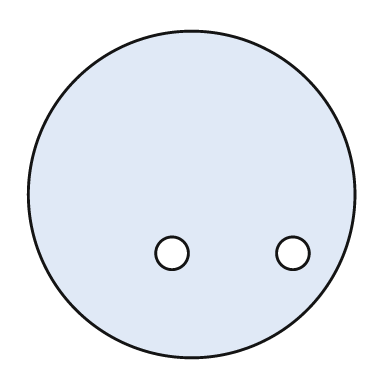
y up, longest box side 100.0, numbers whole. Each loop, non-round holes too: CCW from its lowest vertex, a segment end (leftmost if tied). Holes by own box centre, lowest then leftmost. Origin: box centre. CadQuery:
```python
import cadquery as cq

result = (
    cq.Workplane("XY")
    .moveTo(0.0, 0.0)
    .circle(50.0)
    .moveTo(-6.0, -18.0)
    .circle(5.0)
    .moveTo(31.0, -18.0)
    .circle(5.0)
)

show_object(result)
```